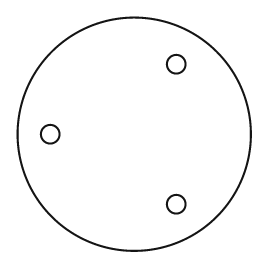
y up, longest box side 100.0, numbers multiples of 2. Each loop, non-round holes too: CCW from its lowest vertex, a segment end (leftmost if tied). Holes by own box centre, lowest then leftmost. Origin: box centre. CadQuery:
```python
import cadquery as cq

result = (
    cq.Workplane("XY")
    .moveTo(0.0, 0.0)
    .circle(50.0)
    .moveTo(18.0, -30.0)
    .circle(4.0)
    .moveTo(-36.0, 0.0)
    .circle(4.0)
    .moveTo(18.0, 30.0)
    .circle(4.0)
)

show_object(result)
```